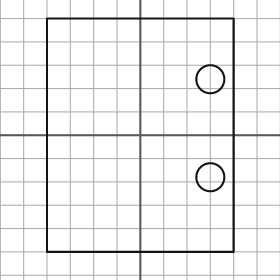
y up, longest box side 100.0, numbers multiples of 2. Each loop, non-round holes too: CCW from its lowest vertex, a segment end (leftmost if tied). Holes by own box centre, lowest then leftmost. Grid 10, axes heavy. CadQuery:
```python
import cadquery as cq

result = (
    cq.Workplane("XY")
    .moveTo(-40.0, -50.0)
    .lineTo(40.0, -50.0)
    .lineTo(40.0, 50.0)
    .lineTo(-40.0, 50.0)
    .close()
    .moveTo(30.0, -18.0)
    .circle(6.0)
    .moveTo(30.0, 24.0)
    .circle(6.0)
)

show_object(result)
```